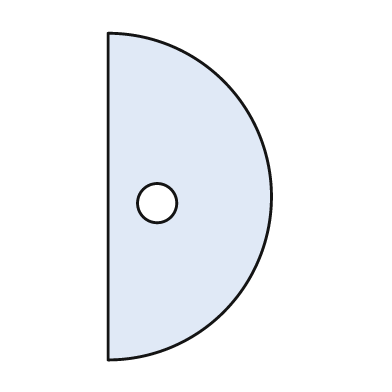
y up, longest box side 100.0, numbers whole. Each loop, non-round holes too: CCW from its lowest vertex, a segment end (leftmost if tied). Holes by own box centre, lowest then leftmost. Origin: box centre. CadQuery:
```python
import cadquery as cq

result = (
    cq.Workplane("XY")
    .moveTo(-25.0, -50.0)
    .threePointArc((25.0, 0.0), (-25.0, 50.0))
    .close()
    .moveTo(-10.0, -2.0)
    .circle(6.0)
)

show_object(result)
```